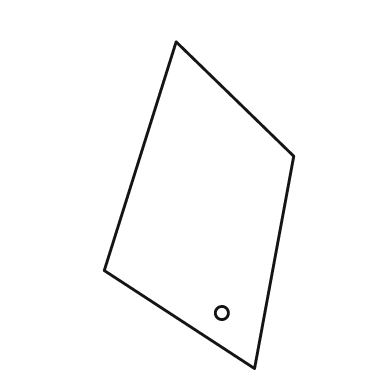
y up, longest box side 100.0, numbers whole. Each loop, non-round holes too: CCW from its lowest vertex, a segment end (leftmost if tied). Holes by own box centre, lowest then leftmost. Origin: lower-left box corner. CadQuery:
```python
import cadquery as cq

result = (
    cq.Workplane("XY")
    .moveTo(46.0, 0.0)
    .lineTo(58.0, 65.0)
    .lineTo(22.0, 100.0)
    .lineTo(0.0, 30.0)
    .close()
    .moveTo(36.0, 17.0)
    .circle(2.0)
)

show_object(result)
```